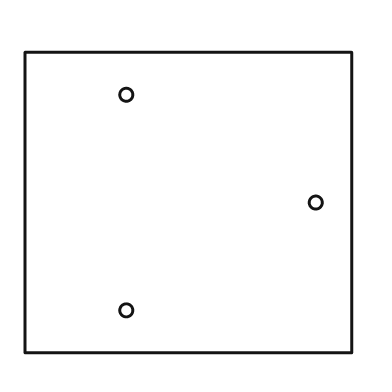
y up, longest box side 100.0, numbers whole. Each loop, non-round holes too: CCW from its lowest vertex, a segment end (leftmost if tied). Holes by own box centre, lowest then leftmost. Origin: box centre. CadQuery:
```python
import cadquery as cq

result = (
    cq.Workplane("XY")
    .moveTo(-50.0, -46.0)
    .lineTo(50.0, -46.0)
    .lineTo(50.0, 46.0)
    .lineTo(-50.0, 46.0)
    .close()
    .moveTo(-19.0, -33.0)
    .circle(2.0)
    .moveTo(39.0, 0.0)
    .circle(2.0)
    .moveTo(-19.0, 33.0)
    .circle(2.0)
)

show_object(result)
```